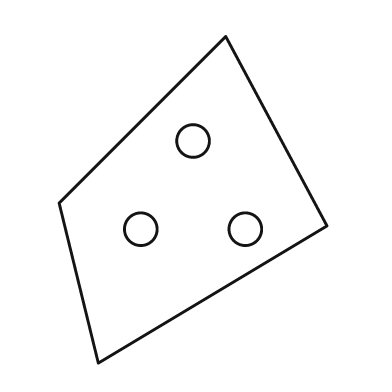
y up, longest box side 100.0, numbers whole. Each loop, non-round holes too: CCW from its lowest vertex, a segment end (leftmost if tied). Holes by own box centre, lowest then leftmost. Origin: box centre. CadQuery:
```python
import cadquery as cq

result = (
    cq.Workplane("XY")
    .moveTo(-29.0, -50.0)
    .lineTo(41.0, -8.0)
    .lineTo(10.0, 50.0)
    .lineTo(-41.0, -1.0)
    .close()
    .moveTo(-16.0, -9.0)
    .circle(5.0)
    .moveTo(16.0, -9.0)
    .circle(5.0)
    .moveTo(0.0, 18.0)
    .circle(5.0)
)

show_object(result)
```